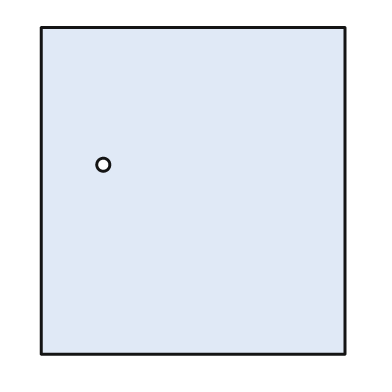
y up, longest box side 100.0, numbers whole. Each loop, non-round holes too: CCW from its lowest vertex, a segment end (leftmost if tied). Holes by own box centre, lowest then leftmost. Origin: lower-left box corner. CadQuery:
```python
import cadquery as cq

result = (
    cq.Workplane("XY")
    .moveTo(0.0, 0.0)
    .lineTo(93.0, 0.0)
    .lineTo(93.0, 100.0)
    .lineTo(0.0, 100.0)
    .close()
    .moveTo(19.0, 58.0)
    .circle(2.0)
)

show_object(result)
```